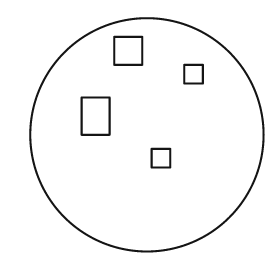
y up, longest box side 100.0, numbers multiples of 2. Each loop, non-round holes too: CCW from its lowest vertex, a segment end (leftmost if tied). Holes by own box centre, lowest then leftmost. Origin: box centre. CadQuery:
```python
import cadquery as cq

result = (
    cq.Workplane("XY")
    .moveTo(0.0, 0.0)
    .circle(50.0)
    .moveTo(2.0, -14.0)
    .lineTo(10.0, -14.0)
    .lineTo(10.0, -6.0)
    .lineTo(2.0, -6.0)
    .close()
    .moveTo(-28.0, 0.0)
    .lineTo(-16.0, 0.0)
    .lineTo(-16.0, 16.0)
    .lineTo(-28.0, 16.0)
    .close()
    .moveTo(16.0, 22.0)
    .lineTo(24.0, 22.0)
    .lineTo(24.0, 30.0)
    .lineTo(16.0, 30.0)
    .close()
    .moveTo(-14.0, 30.0)
    .lineTo(-2.0, 30.0)
    .lineTo(-2.0, 42.0)
    .lineTo(-14.0, 42.0)
    .close()
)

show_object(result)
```